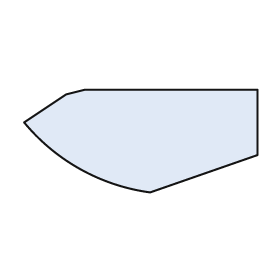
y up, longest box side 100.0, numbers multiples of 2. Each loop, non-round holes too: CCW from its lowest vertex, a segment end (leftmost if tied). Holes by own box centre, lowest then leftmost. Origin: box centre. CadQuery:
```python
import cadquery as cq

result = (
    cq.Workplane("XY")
    .moveTo(4.0, -22.0)
    .lineTo(50.0, -6.0)
    .lineTo(50.0, 22.0)
    .lineTo(-24.0, 22.0)
    .lineTo(-32.0, 20.0)
    .lineTo(-50.0, 8.0)
    .threePointArc((-26.0, -12.0), (4.0, -22.0))
    .close()
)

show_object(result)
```